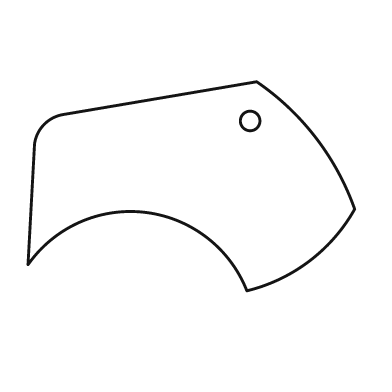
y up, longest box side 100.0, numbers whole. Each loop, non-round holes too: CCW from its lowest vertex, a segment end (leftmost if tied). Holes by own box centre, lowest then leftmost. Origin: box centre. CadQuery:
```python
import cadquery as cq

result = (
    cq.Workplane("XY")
    .moveTo(17.0, -32.0)
    .threePointArc((36.0, -23.0), (50.0, -7.0))
    .threePointArc((38.0, 15.0), (20.0, 32.0))
    .lineTo(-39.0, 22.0)
    .threePointArc((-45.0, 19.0), (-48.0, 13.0))
    .lineTo(-50.0, -24.0)
    .threePointArc((-14.0, -8.0), (17.0, -32.0))
    .close()
    .moveTo(18.0, 20.0)
    .circle(3.0)
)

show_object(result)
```